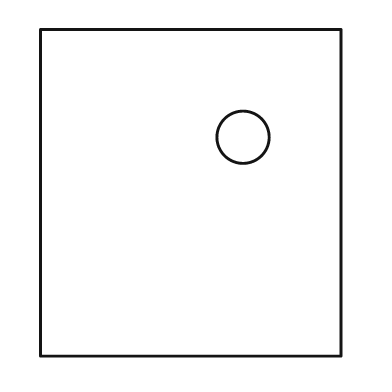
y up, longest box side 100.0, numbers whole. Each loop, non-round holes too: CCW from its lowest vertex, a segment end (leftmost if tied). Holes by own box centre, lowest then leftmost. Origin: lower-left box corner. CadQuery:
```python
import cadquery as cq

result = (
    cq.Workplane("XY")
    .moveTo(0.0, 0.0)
    .lineTo(92.0, 0.0)
    .lineTo(92.0, 100.0)
    .lineTo(0.0, 100.0)
    .close()
    .moveTo(62.0, 67.0)
    .circle(8.0)
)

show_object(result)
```